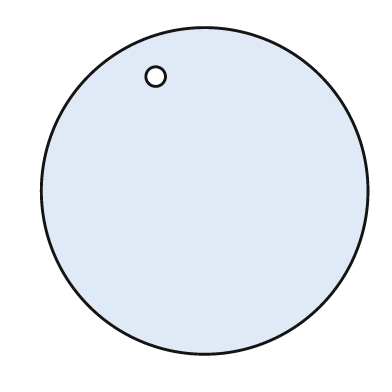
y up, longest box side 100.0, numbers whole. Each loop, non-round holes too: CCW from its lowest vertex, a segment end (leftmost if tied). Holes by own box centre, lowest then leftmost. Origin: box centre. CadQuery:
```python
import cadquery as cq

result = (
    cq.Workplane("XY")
    .moveTo(0.0, 0.0)
    .circle(50.0)
    .moveTo(-15.0, 35.0)
    .circle(3.0)
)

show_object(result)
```